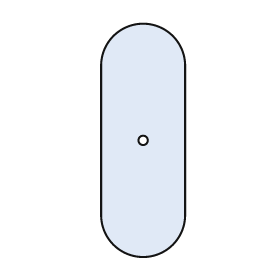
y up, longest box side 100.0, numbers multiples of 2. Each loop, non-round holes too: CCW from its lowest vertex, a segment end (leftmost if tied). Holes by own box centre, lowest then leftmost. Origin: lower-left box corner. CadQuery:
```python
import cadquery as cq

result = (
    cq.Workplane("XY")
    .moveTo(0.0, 18.0)
    .threePointArc((18.0, 0.0), (36.0, 18.0))
    .lineTo(36.0, 82.0)
    .threePointArc((18.0, 100.0), (0.0, 82.0))
    .close()
    .moveTo(18.0, 50.0)
    .circle(2.0)
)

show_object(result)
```